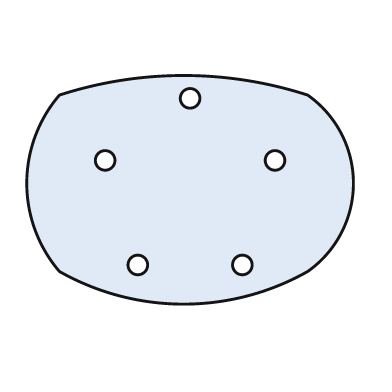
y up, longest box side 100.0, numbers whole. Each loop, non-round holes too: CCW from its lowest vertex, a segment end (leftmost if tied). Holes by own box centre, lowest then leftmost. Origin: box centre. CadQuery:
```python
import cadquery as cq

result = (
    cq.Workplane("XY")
    .moveTo(-40.0, -25.0)
    .threePointArc((-2.0, -35.0), (36.0, -25.0))
    .threePointArc((50.0, 2.0), (36.0, 29.0))
    .threePointArc((-2.0, 35.0), (-40.0, 29.0))
    .threePointArc((-50.0, 2.0), (-40.0, -25.0))
    .close()
    .moveTo(-16.0, -23.0)
    .circle(3.0)
    .moveTo(16.0, -23.0)
    .circle(3.0)
    .moveTo(-26.0, 9.0)
    .circle(3.0)
    .moveTo(26.0, 9.0)
    .circle(3.0)
    .moveTo(0.0, 28.0)
    .circle(3.0)
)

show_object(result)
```